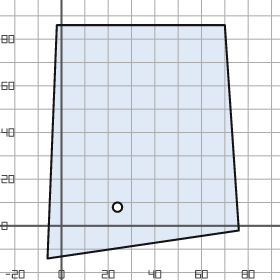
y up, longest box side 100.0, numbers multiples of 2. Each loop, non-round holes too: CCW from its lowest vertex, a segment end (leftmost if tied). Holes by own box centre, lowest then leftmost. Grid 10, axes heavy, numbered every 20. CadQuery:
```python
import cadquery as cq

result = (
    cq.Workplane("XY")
    .moveTo(-6.0, -14.0)
    .lineTo(76.0, -2.0)
    .lineTo(70.0, 86.0)
    .lineTo(-2.0, 86.0)
    .close()
    .moveTo(24.0, 8.0)
    .circle(2.0)
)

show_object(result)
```